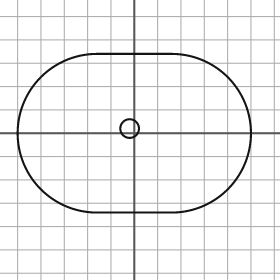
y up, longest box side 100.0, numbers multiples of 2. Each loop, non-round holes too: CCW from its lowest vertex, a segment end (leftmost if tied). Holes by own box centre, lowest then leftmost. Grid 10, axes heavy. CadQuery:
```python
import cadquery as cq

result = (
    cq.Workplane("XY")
    .moveTo(-16.0, -34.0)
    .lineTo(16.0, -34.0)
    .threePointArc((50.0, 0.0), (16.0, 34.0))
    .lineTo(-16.0, 34.0)
    .threePointArc((-50.0, 0.0), (-16.0, -34.0))
    .close()
    .moveTo(-2.0, 2.0)
    .circle(4.0)
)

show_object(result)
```